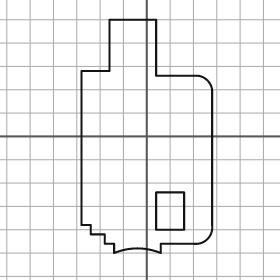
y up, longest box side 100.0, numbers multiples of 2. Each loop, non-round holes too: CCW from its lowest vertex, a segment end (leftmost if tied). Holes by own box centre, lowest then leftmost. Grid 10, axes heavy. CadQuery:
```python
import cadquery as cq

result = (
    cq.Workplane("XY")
    .moveTo(-14.0, -50.0)
    .threePointArc((-4.0, -48.0), (6.0, -50.0))
    .lineTo(6.0, -46.0)
    .lineTo(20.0, -46.0)
    .threePointArc((26.0, -44.0), (28.0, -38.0))
    .lineTo(28.0, 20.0)
    .threePointArc((26.0, 24.0), (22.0, 26.0))
    .lineTo(4.0, 26.0)
    .lineTo(4.0, 50.0)
    .lineTo(-16.0, 50.0)
    .lineTo(-16.0, 28.0)
    .lineTo(-28.0, 28.0)
    .lineTo(-28.0, -38.0)
    .lineTo(-24.0, -38.0)
    .lineTo(-24.0, -42.0)
    .lineTo(-18.0, -42.0)
    .lineTo(-18.0, -46.0)
    .lineTo(-14.0, -46.0)
    .close()
    .moveTo(4.0, -40.0)
    .lineTo(16.0, -40.0)
    .lineTo(16.0, -24.0)
    .lineTo(4.0, -24.0)
    .close()
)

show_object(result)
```